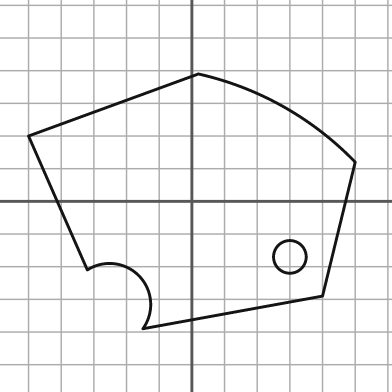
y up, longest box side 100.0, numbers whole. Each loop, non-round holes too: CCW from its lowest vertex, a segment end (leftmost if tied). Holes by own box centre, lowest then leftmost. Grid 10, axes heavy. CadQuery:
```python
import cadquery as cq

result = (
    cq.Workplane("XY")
    .moveTo(-15.0, -39.0)
    .lineTo(40.0, -29.0)
    .lineTo(50.0, 12.0)
    .threePointArc((28.0, 29.0), (2.0, 39.0))
    .lineTo(-50.0, 20.0)
    .lineTo(-32.0, -21.0)
    .threePointArc((-16.0, -23.0), (-15.0, -39.0))
    .close()
    .moveTo(30.0, -17.0)
    .circle(5.0)
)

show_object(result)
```